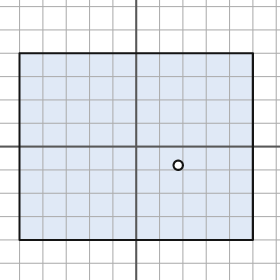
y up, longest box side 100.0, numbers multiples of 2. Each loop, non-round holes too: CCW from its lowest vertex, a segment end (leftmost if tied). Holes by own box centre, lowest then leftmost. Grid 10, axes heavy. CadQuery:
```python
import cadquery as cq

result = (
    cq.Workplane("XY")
    .moveTo(-50.0, -40.0)
    .lineTo(50.0, -40.0)
    .lineTo(50.0, 40.0)
    .lineTo(-50.0, 40.0)
    .close()
    .moveTo(18.0, -8.0)
    .circle(2.0)
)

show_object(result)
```